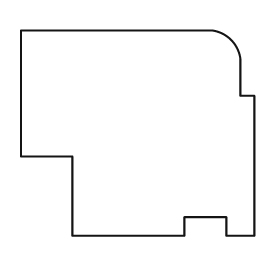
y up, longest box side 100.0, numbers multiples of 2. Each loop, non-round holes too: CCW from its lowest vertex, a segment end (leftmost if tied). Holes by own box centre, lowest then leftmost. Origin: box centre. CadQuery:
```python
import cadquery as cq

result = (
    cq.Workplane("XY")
    .moveTo(-28.0, -44.0)
    .lineTo(20.0, -44.0)
    .lineTo(20.0, -36.0)
    .lineTo(38.0, -36.0)
    .lineTo(38.0, -44.0)
    .lineTo(50.0, -44.0)
    .lineTo(50.0, 16.0)
    .lineTo(44.0, 16.0)
    .lineTo(44.0, 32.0)
    .threePointArc((40.0, 40.0), (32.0, 44.0))
    .lineTo(-50.0, 44.0)
    .lineTo(-50.0, -10.0)
    .lineTo(-28.0, -10.0)
    .close()
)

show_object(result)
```